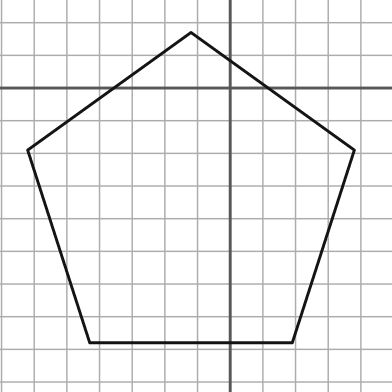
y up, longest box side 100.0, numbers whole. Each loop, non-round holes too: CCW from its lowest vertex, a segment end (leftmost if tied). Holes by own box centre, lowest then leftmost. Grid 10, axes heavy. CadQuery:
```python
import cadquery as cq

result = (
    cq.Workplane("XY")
    .moveTo(-43.0, -78.0)
    .lineTo(19.0, -78.0)
    .lineTo(38.0, -19.0)
    .lineTo(-12.0, 17.0)
    .lineTo(-62.0, -19.0)
    .close()
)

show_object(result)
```